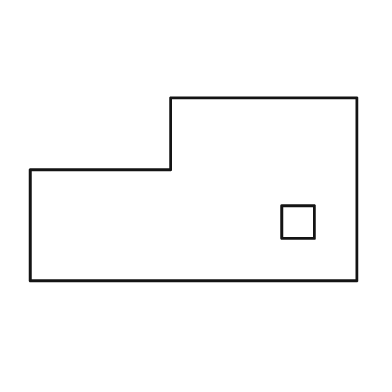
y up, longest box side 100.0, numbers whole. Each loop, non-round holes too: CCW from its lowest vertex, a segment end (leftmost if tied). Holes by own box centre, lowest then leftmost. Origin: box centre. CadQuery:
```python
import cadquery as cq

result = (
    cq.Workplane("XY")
    .moveTo(-50.0, -28.0)
    .lineTo(50.0, -28.0)
    .lineTo(50.0, 28.0)
    .lineTo(-7.0, 28.0)
    .lineTo(-7.0, 6.0)
    .lineTo(-50.0, 6.0)
    .close()
    .moveTo(27.0, -15.0)
    .lineTo(37.0, -15.0)
    .lineTo(37.0, -5.0)
    .lineTo(27.0, -5.0)
    .close()
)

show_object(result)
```